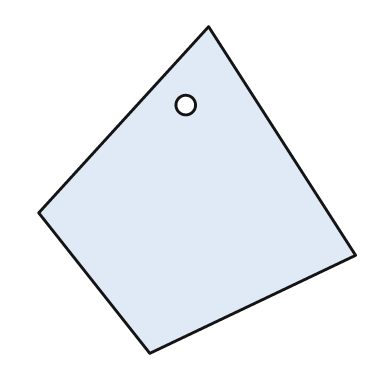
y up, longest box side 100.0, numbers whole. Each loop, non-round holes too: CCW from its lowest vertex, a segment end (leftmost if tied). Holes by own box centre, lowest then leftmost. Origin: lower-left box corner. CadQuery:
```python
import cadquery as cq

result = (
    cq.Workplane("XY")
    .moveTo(34.0, 0.0)
    .lineTo(97.0, 30.0)
    .lineTo(52.0, 100.0)
    .lineTo(0.0, 43.0)
    .close()
    .moveTo(45.0, 76.0)
    .circle(3.0)
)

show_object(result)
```